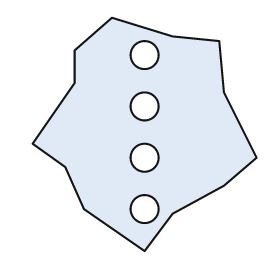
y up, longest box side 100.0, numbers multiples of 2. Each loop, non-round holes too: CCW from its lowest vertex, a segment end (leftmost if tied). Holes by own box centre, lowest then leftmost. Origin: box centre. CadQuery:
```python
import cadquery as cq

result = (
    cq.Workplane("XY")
    .moveTo(0.0, -50.0)
    .lineTo(12.0, -34.0)
    .lineTo(34.0, -22.0)
    .lineTo(48.0, -10.0)
    .lineTo(34.0, 18.0)
    .lineTo(32.0, 40.0)
    .lineTo(12.0, 42.0)
    .lineTo(-14.0, 50.0)
    .lineTo(-30.0, 36.0)
    .lineTo(-30.0, 22.0)
    .lineTo(-48.0, -4.0)
    .lineTo(-34.0, -14.0)
    .lineTo(-26.0, -32.0)
    .close()
    .moveTo(0.0, -32.0)
    .circle(6.0)
    .moveTo(0.0, -10.0)
    .circle(6.0)
    .moveTo(0.0, 12.0)
    .circle(6.0)
    .moveTo(0.0, 34.0)
    .circle(6.0)
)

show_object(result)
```